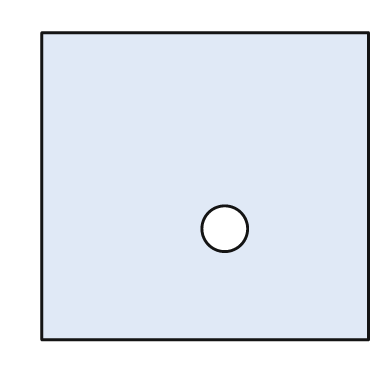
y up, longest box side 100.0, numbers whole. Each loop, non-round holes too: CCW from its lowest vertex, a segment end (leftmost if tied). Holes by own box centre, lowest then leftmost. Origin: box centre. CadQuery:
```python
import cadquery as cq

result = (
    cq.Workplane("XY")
    .moveTo(-50.0, -47.0)
    .lineTo(50.0, -47.0)
    .lineTo(50.0, 47.0)
    .lineTo(-50.0, 47.0)
    .close()
    .moveTo(6.0, -13.0)
    .circle(7.0)
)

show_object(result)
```